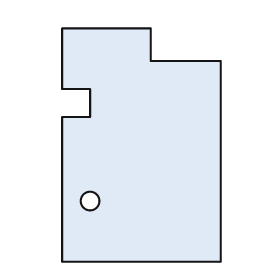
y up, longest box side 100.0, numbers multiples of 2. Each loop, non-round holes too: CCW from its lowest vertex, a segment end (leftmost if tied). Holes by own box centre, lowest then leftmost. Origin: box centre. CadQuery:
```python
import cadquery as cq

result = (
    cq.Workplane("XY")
    .moveTo(-34.0, -50.0)
    .lineTo(34.0, -50.0)
    .lineTo(34.0, 36.0)
    .lineTo(4.0, 36.0)
    .lineTo(4.0, 50.0)
    .lineTo(-34.0, 50.0)
    .lineTo(-34.0, 24.0)
    .lineTo(-22.0, 24.0)
    .lineTo(-22.0, 12.0)
    .lineTo(-34.0, 12.0)
    .close()
    .moveTo(-22.0, -24.0)
    .circle(4.0)
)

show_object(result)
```